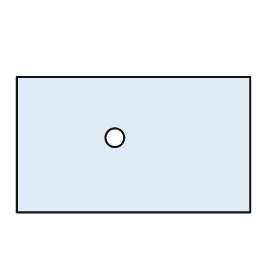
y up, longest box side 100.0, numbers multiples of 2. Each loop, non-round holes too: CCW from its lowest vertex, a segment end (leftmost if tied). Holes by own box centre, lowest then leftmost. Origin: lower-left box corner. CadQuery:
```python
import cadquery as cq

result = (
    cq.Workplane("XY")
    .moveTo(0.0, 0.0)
    .lineTo(100.0, 0.0)
    .lineTo(100.0, 58.0)
    .lineTo(0.0, 58.0)
    .close()
    .moveTo(42.0, 32.0)
    .circle(4.0)
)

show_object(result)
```